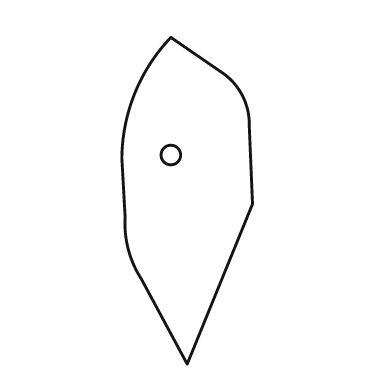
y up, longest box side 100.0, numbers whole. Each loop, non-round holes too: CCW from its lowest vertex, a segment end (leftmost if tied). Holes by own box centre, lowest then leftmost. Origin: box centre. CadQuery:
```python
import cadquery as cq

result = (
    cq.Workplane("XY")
    .moveTo(0.0, -50.0)
    .lineTo(20.0, -1.0)
    .lineTo(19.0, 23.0)
    .threePointArc((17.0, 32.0), (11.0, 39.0))
    .lineTo(-5.0, 50.0)
    .threePointArc((-16.0, 33.0), (-20.0, 13.0))
    .lineTo(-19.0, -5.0)
    .threePointArc((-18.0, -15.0), (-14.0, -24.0))
    .close()
    .moveTo(-5.0, 14.0)
    .circle(3.0)
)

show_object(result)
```